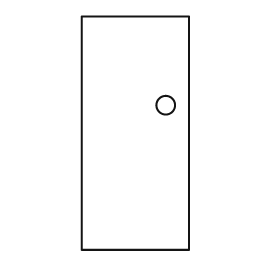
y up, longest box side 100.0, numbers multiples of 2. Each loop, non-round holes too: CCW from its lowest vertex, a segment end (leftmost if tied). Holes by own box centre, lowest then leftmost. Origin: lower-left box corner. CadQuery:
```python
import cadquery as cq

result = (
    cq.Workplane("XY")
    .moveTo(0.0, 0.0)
    .lineTo(46.0, 0.0)
    .lineTo(46.0, 100.0)
    .lineTo(0.0, 100.0)
    .close()
    .moveTo(36.0, 62.0)
    .circle(4.0)
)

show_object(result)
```